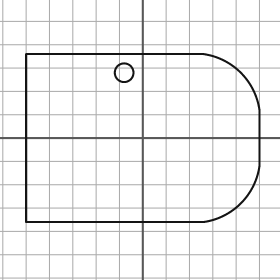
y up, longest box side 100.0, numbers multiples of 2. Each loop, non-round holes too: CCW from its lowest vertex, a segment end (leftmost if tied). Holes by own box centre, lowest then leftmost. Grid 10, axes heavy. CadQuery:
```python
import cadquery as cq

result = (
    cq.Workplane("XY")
    .moveTo(-50.0, -36.0)
    .lineTo(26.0, -36.0)
    .threePointArc((42.0, -28.0), (50.0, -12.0))
    .lineTo(50.0, 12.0)
    .threePointArc((42.0, 28.0), (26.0, 36.0))
    .lineTo(-50.0, 36.0)
    .close()
    .moveTo(-8.0, 28.0)
    .circle(4.0)
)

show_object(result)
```